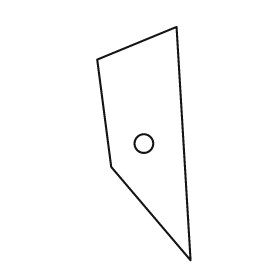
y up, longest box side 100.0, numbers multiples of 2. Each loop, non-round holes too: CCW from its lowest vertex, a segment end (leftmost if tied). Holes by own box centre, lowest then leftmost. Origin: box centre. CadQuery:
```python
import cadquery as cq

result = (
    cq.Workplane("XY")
    .moveTo(20.0, -50.0)
    .lineTo(14.0, 50.0)
    .lineTo(-20.0, 36.0)
    .lineTo(-14.0, -10.0)
    .close()
    .moveTo(0.0, 0.0)
    .circle(4.0)
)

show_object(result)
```